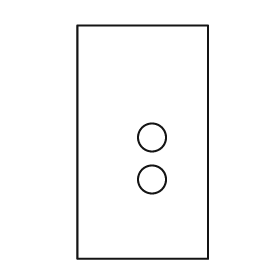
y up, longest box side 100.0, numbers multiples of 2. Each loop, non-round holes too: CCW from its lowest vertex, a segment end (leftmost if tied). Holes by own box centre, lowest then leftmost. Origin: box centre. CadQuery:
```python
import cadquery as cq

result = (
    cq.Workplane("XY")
    .moveTo(-28.0, -50.0)
    .lineTo(28.0, -50.0)
    .lineTo(28.0, 50.0)
    .lineTo(-28.0, 50.0)
    .close()
    .moveTo(4.0, -16.0)
    .circle(6.0)
    .moveTo(4.0, 2.0)
    .circle(6.0)
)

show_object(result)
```